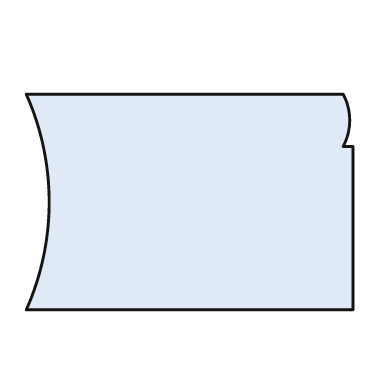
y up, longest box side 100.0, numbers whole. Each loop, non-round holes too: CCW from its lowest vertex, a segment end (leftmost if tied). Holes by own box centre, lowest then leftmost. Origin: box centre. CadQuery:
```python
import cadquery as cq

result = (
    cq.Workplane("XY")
    .moveTo(-50.0, -33.0)
    .lineTo(50.0, -33.0)
    .lineTo(50.0, 17.0)
    .lineTo(47.0, 17.0)
    .threePointArc((49.0, 25.0), (47.0, 33.0))
    .lineTo(-50.0, 33.0)
    .threePointArc((-43.0, 0.0), (-50.0, -33.0))
    .close()
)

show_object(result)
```